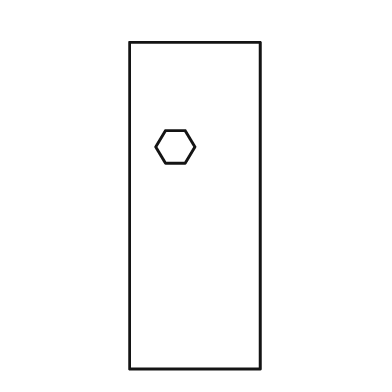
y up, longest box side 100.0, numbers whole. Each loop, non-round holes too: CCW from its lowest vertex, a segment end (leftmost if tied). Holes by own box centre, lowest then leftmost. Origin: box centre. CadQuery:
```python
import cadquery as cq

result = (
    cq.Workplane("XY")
    .moveTo(-20.0, -50.0)
    .lineTo(20.0, -50.0)
    .lineTo(20.0, 50.0)
    .lineTo(-20.0, 50.0)
    .close()
    .moveTo(-9.0, 13.0)
    .lineTo(-3.0, 13.0)
    .lineTo(0.0, 18.0)
    .lineTo(-3.0, 23.0)
    .lineTo(-9.0, 23.0)
    .lineTo(-12.0, 18.0)
    .close()
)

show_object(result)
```